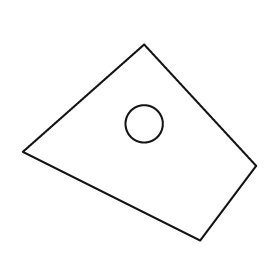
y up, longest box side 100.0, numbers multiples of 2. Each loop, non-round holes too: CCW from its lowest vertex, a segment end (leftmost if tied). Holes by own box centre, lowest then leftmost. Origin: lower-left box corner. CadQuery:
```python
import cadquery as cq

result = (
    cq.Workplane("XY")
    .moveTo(76.0, 0.0)
    .lineTo(100.0, 32.0)
    .lineTo(52.0, 84.0)
    .lineTo(0.0, 38.0)
    .close()
    .moveTo(52.0, 50.0)
    .circle(8.0)
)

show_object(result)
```